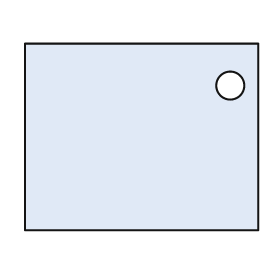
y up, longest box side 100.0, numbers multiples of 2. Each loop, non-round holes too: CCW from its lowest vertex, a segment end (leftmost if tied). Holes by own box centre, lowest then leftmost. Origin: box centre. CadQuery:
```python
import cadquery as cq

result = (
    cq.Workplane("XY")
    .moveTo(-50.0, -40.0)
    .lineTo(50.0, -40.0)
    .lineTo(50.0, 40.0)
    .lineTo(-50.0, 40.0)
    .close()
    .moveTo(38.0, 22.0)
    .circle(6.0)
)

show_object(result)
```